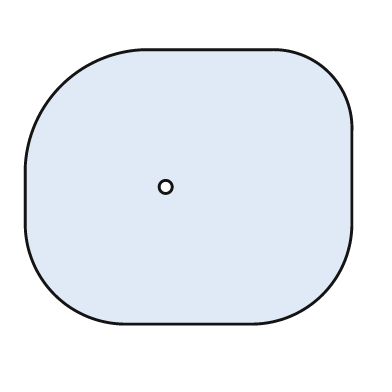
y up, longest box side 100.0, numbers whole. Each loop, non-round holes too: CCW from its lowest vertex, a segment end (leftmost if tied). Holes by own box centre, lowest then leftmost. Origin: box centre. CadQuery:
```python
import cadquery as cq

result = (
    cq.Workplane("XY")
    .moveTo(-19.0, -42.0)
    .lineTo(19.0, -42.0)
    .threePointArc((41.0, -33.0), (50.0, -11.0))
    .lineTo(50.0, 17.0)
    .threePointArc((43.0, 35.0), (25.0, 42.0))
    .lineTo(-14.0, 42.0)
    .threePointArc((-39.0, 31.0), (-50.0, 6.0))
    .lineTo(-50.0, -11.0)
    .threePointArc((-41.0, -33.0), (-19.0, -42.0))
    .close()
    .moveTo(-7.0, 0.0)
    .circle(2.0)
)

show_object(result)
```